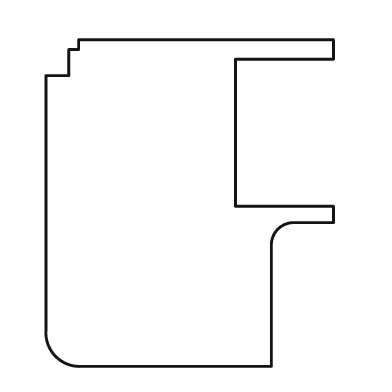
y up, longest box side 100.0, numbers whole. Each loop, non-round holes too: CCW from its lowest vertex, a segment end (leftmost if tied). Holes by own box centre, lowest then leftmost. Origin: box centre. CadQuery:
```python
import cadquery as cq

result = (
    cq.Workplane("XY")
    .moveTo(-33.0, -50.0)
    .lineTo(25.0, -50.0)
    .lineTo(25.0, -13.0)
    .threePointArc((27.0, -8.0), (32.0, -6.0))
    .lineTo(44.0, -6.0)
    .lineTo(44.0, -1.0)
    .lineTo(14.0, -1.0)
    .lineTo(14.0, 44.0)
    .lineTo(44.0, 44.0)
    .lineTo(44.0, 50.0)
    .lineTo(-34.0, 50.0)
    .lineTo(-34.0, 47.0)
    .lineTo(-37.0, 47.0)
    .lineTo(-37.0, 39.0)
    .lineTo(-44.0, 39.0)
    .lineTo(-44.0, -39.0)
    .threePointArc((-41.0, -47.0), (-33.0, -50.0))
    .close()
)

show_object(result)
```